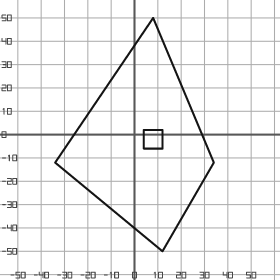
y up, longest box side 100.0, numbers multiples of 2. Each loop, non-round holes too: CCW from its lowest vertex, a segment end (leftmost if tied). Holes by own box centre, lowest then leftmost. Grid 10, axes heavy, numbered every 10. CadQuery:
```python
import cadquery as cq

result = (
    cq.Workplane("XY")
    .moveTo(12.0, -50.0)
    .lineTo(34.0, -12.0)
    .lineTo(8.0, 50.0)
    .lineTo(-34.0, -12.0)
    .close()
    .moveTo(4.0, -6.0)
    .lineTo(12.0, -6.0)
    .lineTo(12.0, 2.0)
    .lineTo(4.0, 2.0)
    .close()
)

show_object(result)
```